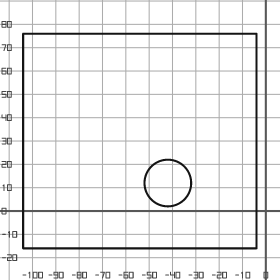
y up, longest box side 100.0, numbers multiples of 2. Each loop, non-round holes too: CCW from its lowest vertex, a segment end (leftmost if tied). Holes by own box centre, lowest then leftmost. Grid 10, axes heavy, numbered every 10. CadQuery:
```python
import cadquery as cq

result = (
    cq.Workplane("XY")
    .moveTo(-104.0, -16.0)
    .lineTo(-4.0, -16.0)
    .lineTo(-4.0, 76.0)
    .lineTo(-104.0, 76.0)
    .close()
    .moveTo(-42.0, 12.0)
    .circle(10.0)
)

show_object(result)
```